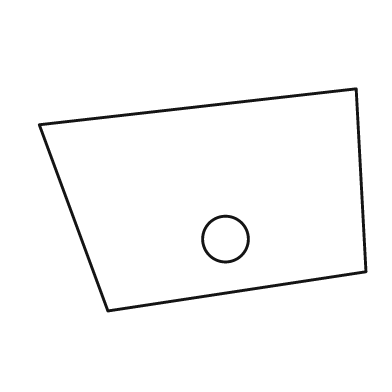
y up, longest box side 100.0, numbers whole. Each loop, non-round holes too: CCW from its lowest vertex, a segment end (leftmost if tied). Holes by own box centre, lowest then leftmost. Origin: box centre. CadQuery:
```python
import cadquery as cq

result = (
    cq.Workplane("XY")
    .moveTo(-29.0, -34.0)
    .lineTo(50.0, -22.0)
    .lineTo(47.0, 34.0)
    .lineTo(-50.0, 23.0)
    .close()
    .moveTo(7.0, -12.0)
    .circle(7.0)
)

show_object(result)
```